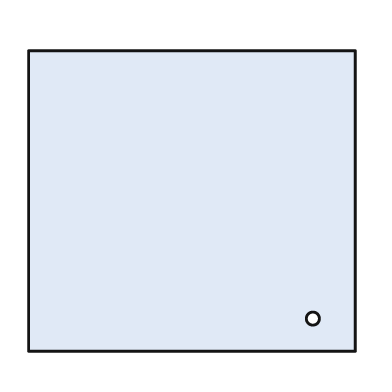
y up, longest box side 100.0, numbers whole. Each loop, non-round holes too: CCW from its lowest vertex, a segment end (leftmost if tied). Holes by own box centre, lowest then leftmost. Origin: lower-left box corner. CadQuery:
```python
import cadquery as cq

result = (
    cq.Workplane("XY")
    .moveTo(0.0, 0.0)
    .lineTo(100.0, 0.0)
    .lineTo(100.0, 92.0)
    .lineTo(0.0, 92.0)
    .close()
    .moveTo(87.0, 10.0)
    .circle(2.0)
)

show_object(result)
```